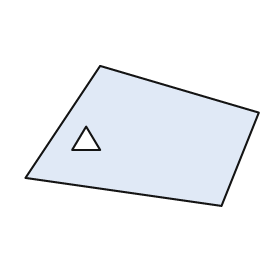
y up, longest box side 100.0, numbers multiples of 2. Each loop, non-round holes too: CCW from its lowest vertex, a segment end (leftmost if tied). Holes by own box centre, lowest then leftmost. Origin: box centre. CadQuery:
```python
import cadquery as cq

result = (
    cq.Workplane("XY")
    .moveTo(34.0, -30.0)
    .lineTo(50.0, 10.0)
    .lineTo(-18.0, 30.0)
    .lineTo(-50.0, -18.0)
    .close()
    .moveTo(-30.0, -6.0)
    .lineTo(-18.0, -6.0)
    .lineTo(-24.0, 4.0)
    .close()
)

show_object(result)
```